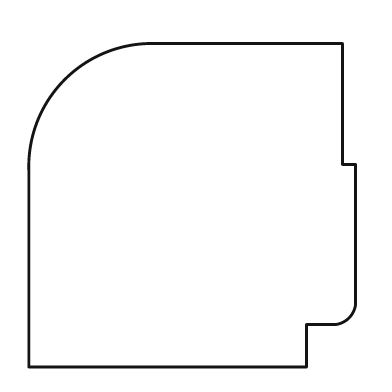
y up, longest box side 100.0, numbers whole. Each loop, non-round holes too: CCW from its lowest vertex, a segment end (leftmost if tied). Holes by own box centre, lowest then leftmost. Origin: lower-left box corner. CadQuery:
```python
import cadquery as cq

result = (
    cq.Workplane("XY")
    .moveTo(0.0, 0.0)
    .lineTo(85.0, 0.0)
    .lineTo(85.0, 13.0)
    .lineTo(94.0, 13.0)
    .threePointArc((98.0, 15.0), (100.0, 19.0))
    .lineTo(100.0, 62.0)
    .lineTo(96.0, 62.0)
    .lineTo(96.0, 99.0)
    .lineTo(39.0, 99.0)
    .threePointArc((11.0, 88.0), (0.0, 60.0))
    .close()
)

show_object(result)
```